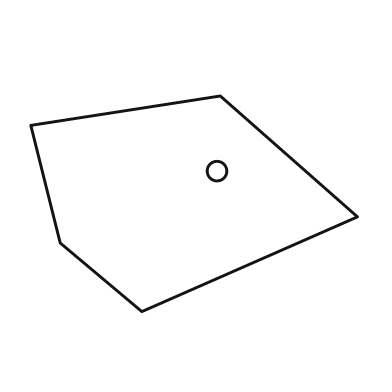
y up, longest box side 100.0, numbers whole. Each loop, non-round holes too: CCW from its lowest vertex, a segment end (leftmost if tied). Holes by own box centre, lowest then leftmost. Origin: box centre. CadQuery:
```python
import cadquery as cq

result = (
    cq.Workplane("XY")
    .moveTo(-16.0, -33.0)
    .lineTo(50.0, -4.0)
    .lineTo(8.0, 33.0)
    .lineTo(-50.0, 24.0)
    .lineTo(-41.0, -12.0)
    .close()
    .moveTo(7.0, 10.0)
    .circle(3.0)
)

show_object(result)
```